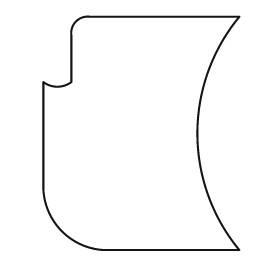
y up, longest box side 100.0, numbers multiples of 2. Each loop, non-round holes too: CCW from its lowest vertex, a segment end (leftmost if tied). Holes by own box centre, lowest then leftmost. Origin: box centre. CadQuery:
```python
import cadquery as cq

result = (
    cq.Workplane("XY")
    .moveTo(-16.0, -50.0)
    .lineTo(42.0, -50.0)
    .threePointArc((24.0, 0.0), (42.0, 50.0))
    .lineTo(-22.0, 50.0)
    .threePointArc((-28.0, 48.0), (-30.0, 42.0))
    .lineTo(-30.0, 22.0)
    .threePointArc((-36.0, 20.0), (-42.0, 22.0))
    .lineTo(-42.0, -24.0)
    .threePointArc((-34.0, -42.0), (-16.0, -50.0))
    .close()
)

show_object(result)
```